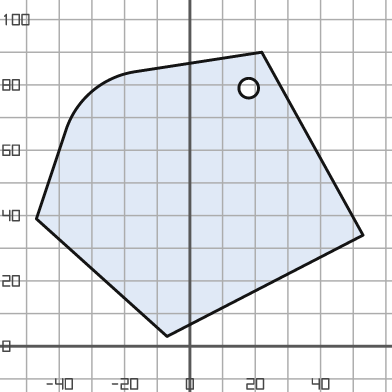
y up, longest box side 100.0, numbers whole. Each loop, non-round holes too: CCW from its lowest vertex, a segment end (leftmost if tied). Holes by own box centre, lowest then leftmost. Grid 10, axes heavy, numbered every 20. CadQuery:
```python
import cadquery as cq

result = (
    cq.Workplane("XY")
    .moveTo(-7.0, 3.0)
    .lineTo(53.0, 34.0)
    .lineTo(22.0, 90.0)
    .lineTo(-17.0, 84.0)
    .threePointArc((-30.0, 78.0), (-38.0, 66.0))
    .lineTo(-47.0, 39.0)
    .close()
    .moveTo(18.0, 79.0)
    .circle(3.0)
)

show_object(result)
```